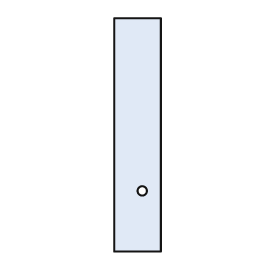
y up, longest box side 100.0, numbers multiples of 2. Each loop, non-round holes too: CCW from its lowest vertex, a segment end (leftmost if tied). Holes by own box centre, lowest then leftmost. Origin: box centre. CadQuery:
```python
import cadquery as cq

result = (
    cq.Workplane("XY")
    .moveTo(-10.0, -50.0)
    .lineTo(10.0, -50.0)
    .lineTo(10.0, 50.0)
    .lineTo(-10.0, 50.0)
    .close()
    .moveTo(2.0, -24.0)
    .circle(2.0)
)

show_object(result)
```